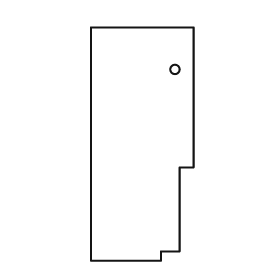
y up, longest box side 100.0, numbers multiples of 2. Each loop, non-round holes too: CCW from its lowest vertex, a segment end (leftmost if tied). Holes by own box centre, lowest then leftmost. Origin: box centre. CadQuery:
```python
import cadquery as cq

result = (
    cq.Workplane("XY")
    .moveTo(-22.0, -50.0)
    .lineTo(8.0, -50.0)
    .lineTo(8.0, -46.0)
    .lineTo(16.0, -46.0)
    .lineTo(16.0, -10.0)
    .lineTo(22.0, -10.0)
    .lineTo(22.0, 50.0)
    .lineTo(-22.0, 50.0)
    .close()
    .moveTo(14.0, 32.0)
    .circle(2.0)
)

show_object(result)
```